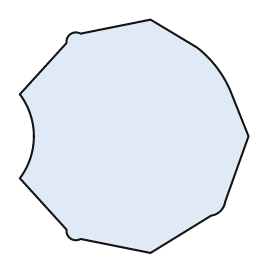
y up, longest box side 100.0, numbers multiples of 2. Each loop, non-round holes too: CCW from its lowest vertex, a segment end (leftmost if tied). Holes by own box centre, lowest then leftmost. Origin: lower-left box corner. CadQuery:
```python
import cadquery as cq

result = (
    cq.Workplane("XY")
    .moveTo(56.0, 0.0)
    .lineTo(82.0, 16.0)
    .threePointArc((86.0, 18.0), (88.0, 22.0))
    .lineTo(98.0, 50.0)
    .lineTo(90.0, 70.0)
    .threePointArc((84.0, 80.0), (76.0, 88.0))
    .lineTo(56.0, 100.0)
    .lineTo(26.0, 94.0)
    .threePointArc((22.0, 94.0), (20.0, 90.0))
    .lineTo(0.0, 68.0)
    .threePointArc((6.0, 50.0), (0.0, 32.0))
    .lineTo(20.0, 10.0)
    .threePointArc((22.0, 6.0), (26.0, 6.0))
    .close()
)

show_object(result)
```